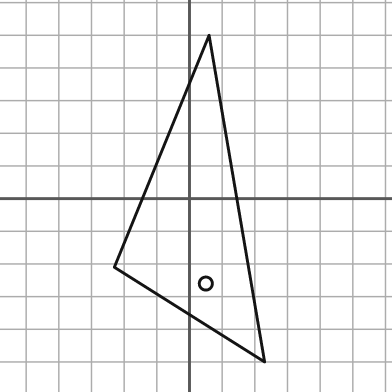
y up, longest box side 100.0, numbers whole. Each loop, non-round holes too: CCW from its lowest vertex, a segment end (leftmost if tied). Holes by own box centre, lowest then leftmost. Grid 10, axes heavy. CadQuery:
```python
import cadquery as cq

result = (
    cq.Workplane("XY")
    .moveTo(23.0, -50.0)
    .lineTo(6.0, 50.0)
    .lineTo(-23.0, -21.0)
    .close()
    .moveTo(5.0, -26.0)
    .circle(2.0)
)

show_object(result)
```